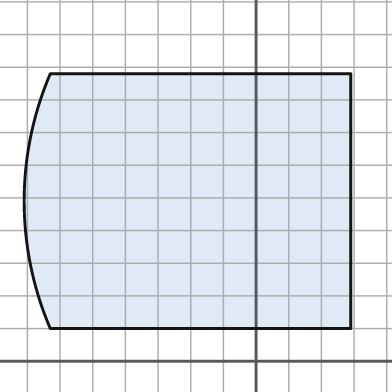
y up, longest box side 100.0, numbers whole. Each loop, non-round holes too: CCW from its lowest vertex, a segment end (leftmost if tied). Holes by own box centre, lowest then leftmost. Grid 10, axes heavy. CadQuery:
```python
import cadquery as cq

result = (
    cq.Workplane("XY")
    .moveTo(-63.0, 10.0)
    .lineTo(29.0, 10.0)
    .lineTo(29.0, 88.0)
    .lineTo(-63.0, 88.0)
    .threePointArc((-71.0, 49.0), (-63.0, 10.0))
    .close()
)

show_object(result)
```